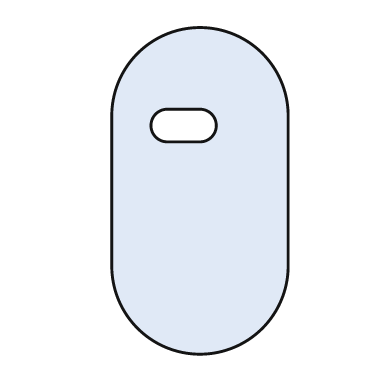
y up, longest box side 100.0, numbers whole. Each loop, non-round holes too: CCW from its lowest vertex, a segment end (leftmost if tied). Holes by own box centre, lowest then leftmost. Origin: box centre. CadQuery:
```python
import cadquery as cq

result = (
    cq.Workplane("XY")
    .moveTo(-27.0, -23.0)
    .threePointArc((0.0, -50.0), (27.0, -23.0))
    .lineTo(27.0, 23.0)
    .threePointArc((0.0, 50.0), (-27.0, 23.0))
    .close()
    .moveTo(-10.0, 15.0)
    .lineTo(0.0, 15.0)
    .threePointArc((5.0, 20.0), (0.0, 25.0))
    .lineTo(-10.0, 25.0)
    .threePointArc((-15.0, 20.0), (-10.0, 15.0))
    .close()
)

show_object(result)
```